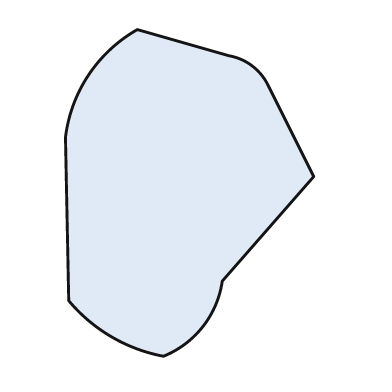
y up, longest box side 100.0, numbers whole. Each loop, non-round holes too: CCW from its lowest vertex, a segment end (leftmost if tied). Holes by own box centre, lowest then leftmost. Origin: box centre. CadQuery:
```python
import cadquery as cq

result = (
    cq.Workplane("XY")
    .moveTo(-8.0, -50.0)
    .threePointArc((4.0, -41.0), (10.0, -27.0))
    .lineTo(38.0, 5.0)
    .lineTo(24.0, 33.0)
    .threePointArc((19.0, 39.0), (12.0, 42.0))
    .lineTo(-16.0, 50.0)
    .threePointArc((-31.0, 36.0), (-38.0, 17.0))
    .lineTo(-37.0, -33.0)
    .threePointArc((-24.0, -44.0), (-8.0, -50.0))
    .close()
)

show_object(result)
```